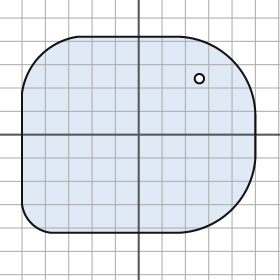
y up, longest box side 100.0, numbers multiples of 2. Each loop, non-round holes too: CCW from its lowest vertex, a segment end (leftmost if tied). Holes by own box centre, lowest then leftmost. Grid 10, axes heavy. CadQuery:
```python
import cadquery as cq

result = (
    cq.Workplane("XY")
    .moveTo(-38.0, -42.0)
    .lineTo(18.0, -42.0)
    .threePointArc((40.0, -32.0), (50.0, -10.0))
    .lineTo(50.0, 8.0)
    .threePointArc((40.0, 32.0), (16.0, 42.0))
    .lineTo(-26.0, 42.0)
    .threePointArc((-42.0, 34.0), (-50.0, 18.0))
    .lineTo(-50.0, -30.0)
    .threePointArc((-46.0, -38.0), (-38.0, -42.0))
    .close()
    .moveTo(26.0, 24.0)
    .circle(2.0)
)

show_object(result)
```